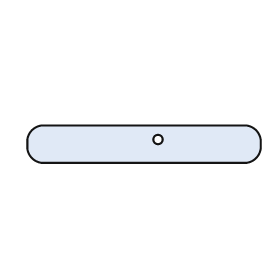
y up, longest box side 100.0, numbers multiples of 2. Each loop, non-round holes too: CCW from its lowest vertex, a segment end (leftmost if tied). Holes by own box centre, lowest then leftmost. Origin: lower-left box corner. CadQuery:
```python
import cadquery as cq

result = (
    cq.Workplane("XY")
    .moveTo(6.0, 0.0)
    .lineTo(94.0, 0.0)
    .threePointArc((98.0, 2.0), (100.0, 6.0))
    .lineTo(100.0, 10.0)
    .threePointArc((98.0, 14.0), (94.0, 16.0))
    .lineTo(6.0, 16.0)
    .threePointArc((2.0, 14.0), (0.0, 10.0))
    .lineTo(0.0, 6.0)
    .threePointArc((2.0, 2.0), (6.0, 0.0))
    .close()
    .moveTo(56.0, 10.0)
    .circle(2.0)
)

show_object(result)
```